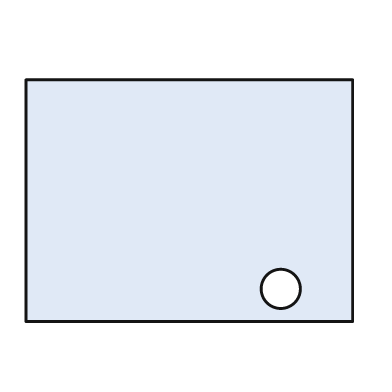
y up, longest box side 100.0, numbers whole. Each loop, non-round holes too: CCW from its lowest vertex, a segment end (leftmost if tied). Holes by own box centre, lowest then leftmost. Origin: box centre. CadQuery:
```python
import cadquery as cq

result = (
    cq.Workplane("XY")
    .moveTo(-50.0, -37.0)
    .lineTo(50.0, -37.0)
    .lineTo(50.0, 37.0)
    .lineTo(-50.0, 37.0)
    .close()
    .moveTo(28.0, -27.0)
    .circle(6.0)
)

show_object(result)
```